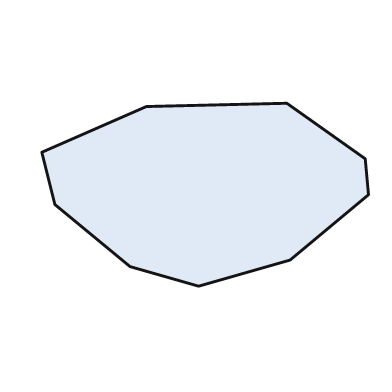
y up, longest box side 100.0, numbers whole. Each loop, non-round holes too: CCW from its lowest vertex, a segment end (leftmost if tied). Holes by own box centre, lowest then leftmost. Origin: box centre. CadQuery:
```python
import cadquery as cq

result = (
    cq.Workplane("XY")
    .moveTo(-2.0, -28.0)
    .lineTo(26.0, -20.0)
    .lineTo(50.0, 0.0)
    .lineTo(49.0, 11.0)
    .lineTo(25.0, 28.0)
    .lineTo(-18.0, 27.0)
    .lineTo(-50.0, 13.0)
    .lineTo(-46.0, -3.0)
    .lineTo(-23.0, -22.0)
    .close()
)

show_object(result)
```